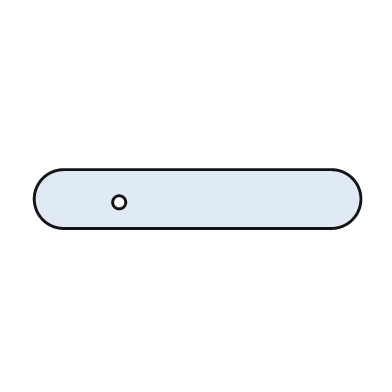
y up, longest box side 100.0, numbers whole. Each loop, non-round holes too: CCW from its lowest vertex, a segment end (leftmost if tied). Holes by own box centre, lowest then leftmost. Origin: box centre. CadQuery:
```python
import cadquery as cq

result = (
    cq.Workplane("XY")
    .moveTo(-41.0, -9.0)
    .lineTo(41.0, -9.0)
    .threePointArc((50.0, 0.0), (41.0, 9.0))
    .lineTo(-41.0, 9.0)
    .threePointArc((-50.0, 0.0), (-41.0, -9.0))
    .close()
    .moveTo(-24.0, -1.0)
    .circle(2.0)
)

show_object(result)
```